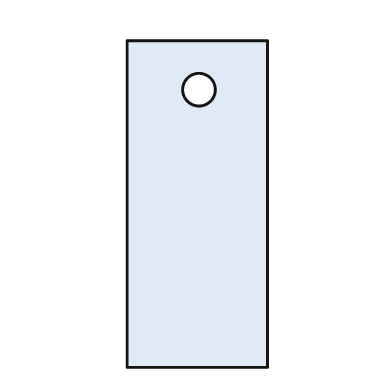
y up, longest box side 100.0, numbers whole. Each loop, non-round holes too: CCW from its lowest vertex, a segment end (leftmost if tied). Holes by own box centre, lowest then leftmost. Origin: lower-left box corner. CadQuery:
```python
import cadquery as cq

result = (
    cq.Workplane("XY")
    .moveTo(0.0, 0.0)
    .lineTo(43.0, 0.0)
    .lineTo(43.0, 100.0)
    .lineTo(0.0, 100.0)
    .close()
    .moveTo(22.0, 85.0)
    .circle(5.0)
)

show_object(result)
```